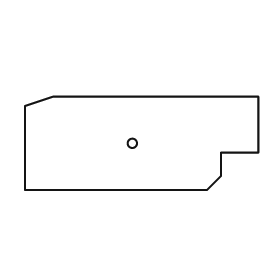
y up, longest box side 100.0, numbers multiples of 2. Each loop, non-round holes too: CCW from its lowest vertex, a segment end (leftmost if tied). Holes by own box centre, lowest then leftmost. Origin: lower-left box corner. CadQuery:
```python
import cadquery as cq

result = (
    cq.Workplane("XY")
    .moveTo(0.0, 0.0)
    .lineTo(78.0, 0.0)
    .lineTo(84.0, 6.0)
    .lineTo(84.0, 16.0)
    .lineTo(100.0, 16.0)
    .lineTo(100.0, 40.0)
    .lineTo(12.0, 40.0)
    .lineTo(0.0, 36.0)
    .close()
    .moveTo(46.0, 20.0)
    .circle(2.0)
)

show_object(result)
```